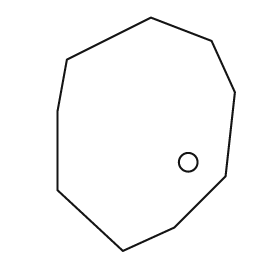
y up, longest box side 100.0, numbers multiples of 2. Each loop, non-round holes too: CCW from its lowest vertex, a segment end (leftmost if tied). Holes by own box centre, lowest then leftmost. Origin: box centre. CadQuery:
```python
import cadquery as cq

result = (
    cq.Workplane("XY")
    .moveTo(-10.0, -50.0)
    .lineTo(12.0, -40.0)
    .lineTo(34.0, -18.0)
    .lineTo(38.0, 18.0)
    .lineTo(28.0, 40.0)
    .lineTo(2.0, 50.0)
    .lineTo(-34.0, 32.0)
    .lineTo(-38.0, 10.0)
    .lineTo(-38.0, -24.0)
    .close()
    .moveTo(18.0, -12.0)
    .circle(4.0)
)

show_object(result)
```